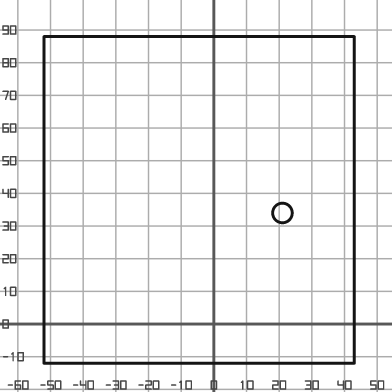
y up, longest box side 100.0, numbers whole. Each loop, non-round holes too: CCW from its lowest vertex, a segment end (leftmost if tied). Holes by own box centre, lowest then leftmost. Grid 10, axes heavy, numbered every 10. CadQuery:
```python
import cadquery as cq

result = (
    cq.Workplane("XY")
    .moveTo(-52.0, -12.0)
    .lineTo(43.0, -12.0)
    .lineTo(43.0, 88.0)
    .lineTo(-52.0, 88.0)
    .close()
    .moveTo(21.0, 34.0)
    .circle(3.0)
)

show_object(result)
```